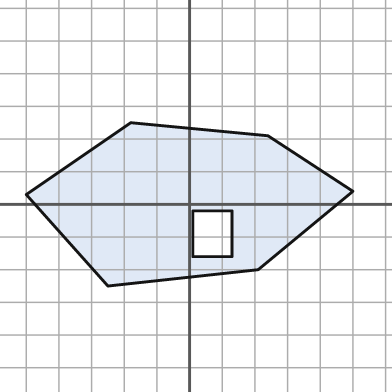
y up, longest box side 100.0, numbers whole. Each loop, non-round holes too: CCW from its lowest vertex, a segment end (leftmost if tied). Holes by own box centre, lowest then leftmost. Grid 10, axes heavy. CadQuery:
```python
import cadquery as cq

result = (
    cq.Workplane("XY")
    .moveTo(-25.0, -25.0)
    .lineTo(21.0, -20.0)
    .lineTo(50.0, 4.0)
    .lineTo(24.0, 21.0)
    .lineTo(-18.0, 25.0)
    .lineTo(-50.0, 3.0)
    .close()
    .moveTo(1.0, -16.0)
    .lineTo(13.0, -16.0)
    .lineTo(13.0, -2.0)
    .lineTo(1.0, -2.0)
    .close()
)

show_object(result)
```